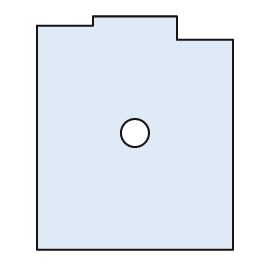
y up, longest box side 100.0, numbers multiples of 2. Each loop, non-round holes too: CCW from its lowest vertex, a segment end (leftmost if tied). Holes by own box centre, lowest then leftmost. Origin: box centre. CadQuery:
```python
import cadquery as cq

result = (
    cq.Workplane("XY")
    .moveTo(-42.0, -50.0)
    .lineTo(42.0, -50.0)
    .lineTo(42.0, 40.0)
    .lineTo(18.0, 40.0)
    .lineTo(18.0, 50.0)
    .lineTo(-18.0, 50.0)
    .lineTo(-18.0, 46.0)
    .lineTo(-42.0, 46.0)
    .close()
    .moveTo(0.0, 0.0)
    .circle(6.0)
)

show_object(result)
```